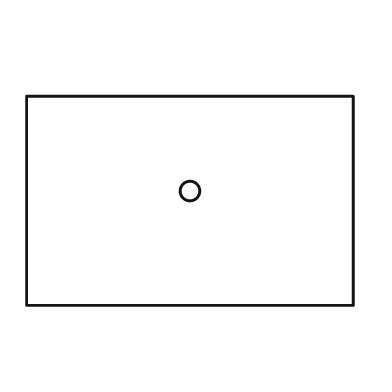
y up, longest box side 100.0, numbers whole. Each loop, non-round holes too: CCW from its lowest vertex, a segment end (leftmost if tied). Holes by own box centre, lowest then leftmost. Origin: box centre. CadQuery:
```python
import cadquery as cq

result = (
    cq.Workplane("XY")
    .moveTo(-50.0, -32.0)
    .lineTo(50.0, -32.0)
    .lineTo(50.0, 32.0)
    .lineTo(-50.0, 32.0)
    .close()
    .moveTo(0.0, 3.0)
    .circle(3.0)
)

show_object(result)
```